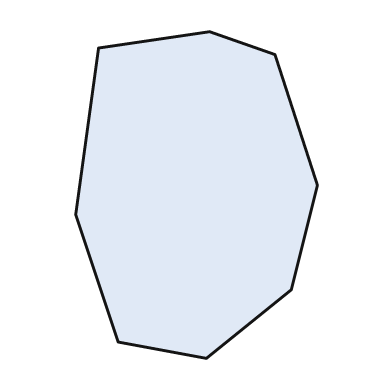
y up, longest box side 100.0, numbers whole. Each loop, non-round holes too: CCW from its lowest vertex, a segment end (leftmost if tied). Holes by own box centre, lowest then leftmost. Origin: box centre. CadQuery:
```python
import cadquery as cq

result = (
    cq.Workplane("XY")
    .moveTo(3.0, -50.0)
    .lineTo(29.0, -29.0)
    .lineTo(37.0, 3.0)
    .lineTo(24.0, 43.0)
    .lineTo(4.0, 50.0)
    .lineTo(-30.0, 45.0)
    .lineTo(-37.0, -6.0)
    .lineTo(-24.0, -45.0)
    .close()
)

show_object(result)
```